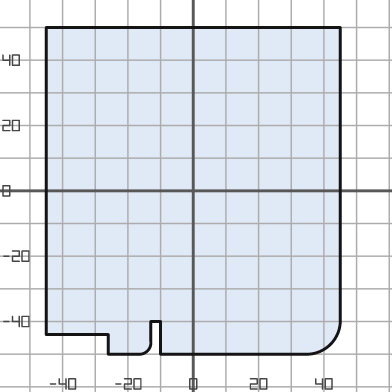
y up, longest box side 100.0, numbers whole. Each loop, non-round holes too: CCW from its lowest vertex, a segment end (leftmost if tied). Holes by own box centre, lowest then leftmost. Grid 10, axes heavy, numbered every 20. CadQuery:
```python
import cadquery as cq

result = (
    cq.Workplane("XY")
    .moveTo(-26.0, -50.0)
    .lineTo(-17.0, -50.0)
    .threePointArc((-14.0, -49.0), (-13.0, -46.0))
    .lineTo(-13.0, -40.0)
    .lineTo(-10.0, -40.0)
    .lineTo(-10.0, -50.0)
    .lineTo(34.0, -50.0)
    .threePointArc((42.0, -47.0), (45.0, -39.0))
    .lineTo(45.0, 50.0)
    .lineTo(-45.0, 50.0)
    .lineTo(-45.0, -44.0)
    .lineTo(-26.0, -44.0)
    .close()
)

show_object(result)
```